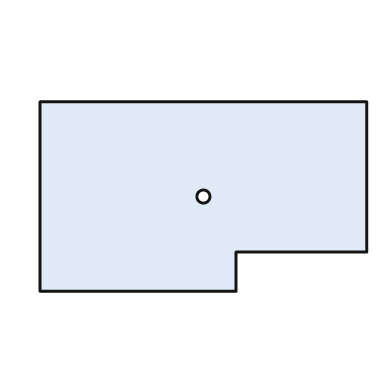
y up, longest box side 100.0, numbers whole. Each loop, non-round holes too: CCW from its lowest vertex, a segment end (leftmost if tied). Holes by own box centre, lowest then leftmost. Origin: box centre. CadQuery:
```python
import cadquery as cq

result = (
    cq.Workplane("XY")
    .moveTo(-50.0, -29.0)
    .lineTo(10.0, -29.0)
    .lineTo(10.0, -17.0)
    .lineTo(50.0, -17.0)
    .lineTo(50.0, 29.0)
    .lineTo(-50.0, 29.0)
    .close()
    .moveTo(0.0, 0.0)
    .circle(2.0)
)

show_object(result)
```